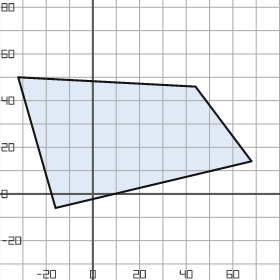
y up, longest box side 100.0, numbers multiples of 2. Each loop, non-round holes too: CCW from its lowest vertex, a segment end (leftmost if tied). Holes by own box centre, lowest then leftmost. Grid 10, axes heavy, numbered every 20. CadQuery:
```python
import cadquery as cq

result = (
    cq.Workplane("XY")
    .moveTo(-16.0, -6.0)
    .lineTo(68.0, 14.0)
    .lineTo(44.0, 46.0)
    .lineTo(-32.0, 50.0)
    .close()
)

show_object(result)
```